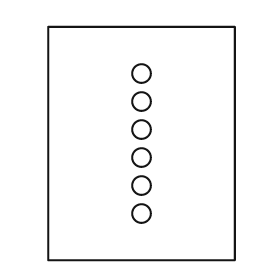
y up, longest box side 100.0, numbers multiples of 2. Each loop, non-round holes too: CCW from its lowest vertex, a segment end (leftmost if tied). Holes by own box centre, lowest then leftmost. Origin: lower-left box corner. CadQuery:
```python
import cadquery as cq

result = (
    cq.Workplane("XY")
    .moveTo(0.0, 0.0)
    .lineTo(80.0, 0.0)
    .lineTo(80.0, 100.0)
    .lineTo(0.0, 100.0)
    .close()
    .moveTo(40.0, 20.0)
    .circle(4.0)
    .moveTo(40.0, 32.0)
    .circle(4.0)
    .moveTo(40.0, 44.0)
    .circle(4.0)
    .moveTo(40.0, 56.0)
    .circle(4.0)
    .moveTo(40.0, 68.0)
    .circle(4.0)
    .moveTo(40.0, 80.0)
    .circle(4.0)
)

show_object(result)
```